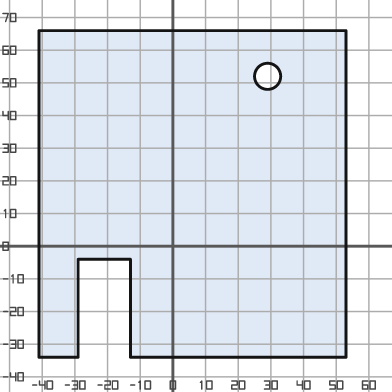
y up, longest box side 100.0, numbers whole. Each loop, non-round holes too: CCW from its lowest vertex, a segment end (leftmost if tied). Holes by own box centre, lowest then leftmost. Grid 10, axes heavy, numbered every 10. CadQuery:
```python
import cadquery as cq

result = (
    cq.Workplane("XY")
    .moveTo(-41.0, -34.0)
    .lineTo(-29.0, -34.0)
    .lineTo(-29.0, -4.0)
    .lineTo(-13.0, -4.0)
    .lineTo(-13.0, -34.0)
    .lineTo(53.0, -34.0)
    .lineTo(53.0, 66.0)
    .lineTo(-41.0, 66.0)
    .close()
    .moveTo(29.0, 52.0)
    .circle(4.0)
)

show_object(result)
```